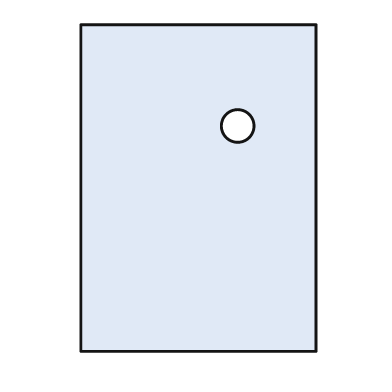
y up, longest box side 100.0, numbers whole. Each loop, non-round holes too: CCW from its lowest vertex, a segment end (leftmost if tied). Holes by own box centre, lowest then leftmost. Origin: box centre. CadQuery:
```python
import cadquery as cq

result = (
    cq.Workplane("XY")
    .moveTo(-36.0, -50.0)
    .lineTo(36.0, -50.0)
    .lineTo(36.0, 50.0)
    .lineTo(-36.0, 50.0)
    .close()
    .moveTo(12.0, 19.0)
    .circle(5.0)
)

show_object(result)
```